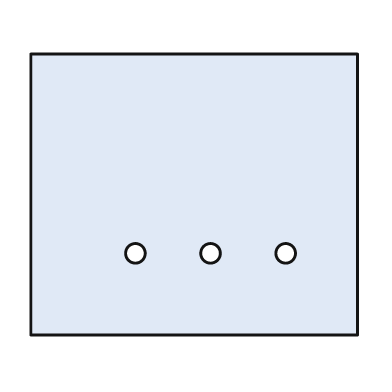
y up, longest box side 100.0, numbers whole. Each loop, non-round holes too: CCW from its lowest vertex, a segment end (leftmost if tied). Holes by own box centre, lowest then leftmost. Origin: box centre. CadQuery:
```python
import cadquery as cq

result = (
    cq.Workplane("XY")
    .moveTo(-50.0, -43.0)
    .lineTo(50.0, -43.0)
    .lineTo(50.0, 43.0)
    .lineTo(-50.0, 43.0)
    .close()
    .moveTo(-18.0, -18.0)
    .circle(3.0)
    .moveTo(5.0, -18.0)
    .circle(3.0)
    .moveTo(28.0, -18.0)
    .circle(3.0)
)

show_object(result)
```